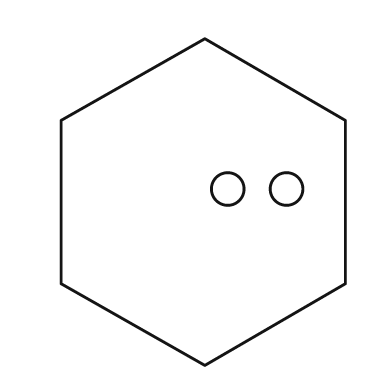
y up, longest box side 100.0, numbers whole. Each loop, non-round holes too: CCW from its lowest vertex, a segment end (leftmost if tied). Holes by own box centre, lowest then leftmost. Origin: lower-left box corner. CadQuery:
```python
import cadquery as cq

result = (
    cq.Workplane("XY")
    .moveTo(44.0, 0.0)
    .lineTo(87.0, 25.0)
    .lineTo(87.0, 75.0)
    .lineTo(44.0, 100.0)
    .lineTo(0.0, 75.0)
    .lineTo(0.0, 25.0)
    .close()
    .moveTo(51.0, 54.0)
    .circle(5.0)
    .moveTo(69.0, 54.0)
    .circle(5.0)
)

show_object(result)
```